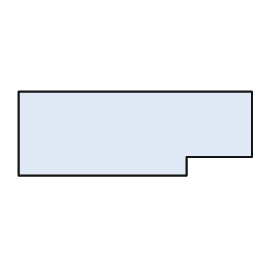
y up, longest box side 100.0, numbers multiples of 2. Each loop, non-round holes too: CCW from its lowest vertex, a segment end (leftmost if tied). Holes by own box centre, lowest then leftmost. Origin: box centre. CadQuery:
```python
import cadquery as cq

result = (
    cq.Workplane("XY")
    .moveTo(-50.0, -18.0)
    .lineTo(22.0, -18.0)
    .lineTo(22.0, -10.0)
    .lineTo(50.0, -10.0)
    .lineTo(50.0, 18.0)
    .lineTo(-50.0, 18.0)
    .close()
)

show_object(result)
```